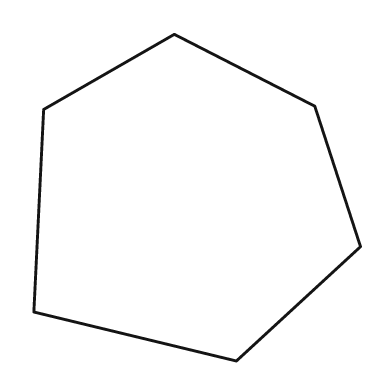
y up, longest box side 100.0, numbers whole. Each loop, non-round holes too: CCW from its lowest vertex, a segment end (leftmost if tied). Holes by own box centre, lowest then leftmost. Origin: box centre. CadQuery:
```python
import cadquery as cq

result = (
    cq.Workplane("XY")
    .moveTo(12.0, -50.0)
    .lineTo(50.0, -15.0)
    .lineTo(36.0, 28.0)
    .lineTo(-7.0, 50.0)
    .lineTo(-47.0, 27.0)
    .lineTo(-50.0, -35.0)
    .close()
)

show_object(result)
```